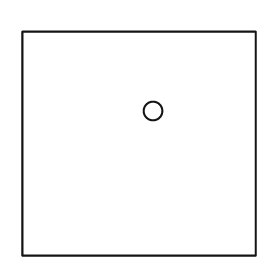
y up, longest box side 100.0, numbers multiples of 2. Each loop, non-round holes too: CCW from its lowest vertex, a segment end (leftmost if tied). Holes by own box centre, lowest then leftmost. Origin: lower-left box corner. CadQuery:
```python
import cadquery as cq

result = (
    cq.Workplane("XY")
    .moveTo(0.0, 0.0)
    .lineTo(100.0, 0.0)
    .lineTo(100.0, 96.0)
    .lineTo(0.0, 96.0)
    .close()
    .moveTo(56.0, 62.0)
    .circle(4.0)
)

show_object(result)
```